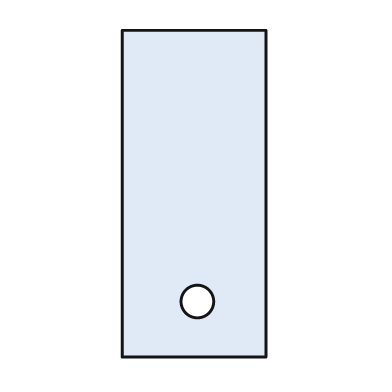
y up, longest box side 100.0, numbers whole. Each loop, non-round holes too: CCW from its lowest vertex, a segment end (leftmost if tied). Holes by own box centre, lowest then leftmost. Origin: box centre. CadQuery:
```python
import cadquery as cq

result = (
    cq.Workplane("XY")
    .moveTo(-22.0, -50.0)
    .lineTo(22.0, -50.0)
    .lineTo(22.0, 50.0)
    .lineTo(-22.0, 50.0)
    .close()
    .moveTo(1.0, -33.0)
    .circle(5.0)
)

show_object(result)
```